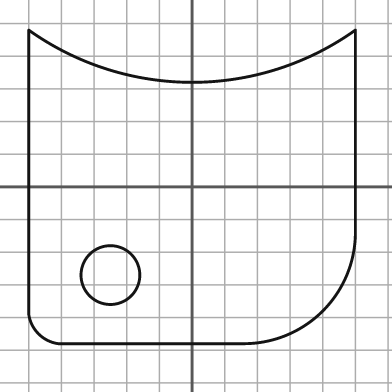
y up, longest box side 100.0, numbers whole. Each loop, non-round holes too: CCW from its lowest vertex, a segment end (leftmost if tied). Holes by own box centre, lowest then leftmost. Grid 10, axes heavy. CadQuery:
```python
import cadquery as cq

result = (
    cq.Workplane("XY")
    .moveTo(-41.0, -48.0)
    .lineTo(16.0, -48.0)
    .threePointArc((40.0, -38.0), (50.0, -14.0))
    .lineTo(50.0, 48.0)
    .threePointArc((0.0, 32.0), (-50.0, 48.0))
    .lineTo(-50.0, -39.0)
    .threePointArc((-47.0, -45.0), (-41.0, -48.0))
    .close()
    .moveTo(-25.0, -27.0)
    .circle(9.0)
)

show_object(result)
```